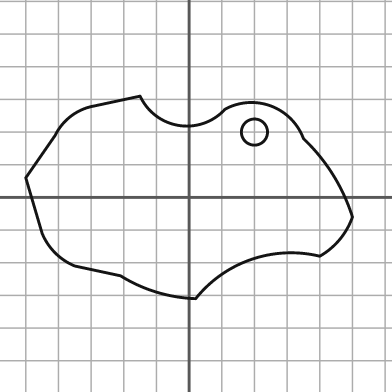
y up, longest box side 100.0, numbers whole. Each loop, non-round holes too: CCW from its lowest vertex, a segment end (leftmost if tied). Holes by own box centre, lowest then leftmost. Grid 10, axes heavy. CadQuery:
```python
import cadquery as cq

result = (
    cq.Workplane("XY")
    .moveTo(2.0, -31.0)
    .threePointArc((19.0, -19.0), (40.0, -18.0))
    .threePointArc((46.0, -13.0), (50.0, -6.0))
    .threePointArc((44.0, 7.0), (35.0, 18.0))
    .threePointArc((25.0, 28.0), (11.0, 27.0))
    .threePointArc((-3.0, 22.0), (-15.0, 31.0))
    .lineTo(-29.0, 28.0)
    .threePointArc((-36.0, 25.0), (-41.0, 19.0))
    .lineTo(-50.0, 6.0)
    .lineTo(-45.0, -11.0)
    .threePointArc((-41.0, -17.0), (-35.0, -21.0))
    .lineTo(-21.0, -24.0)
    .threePointArc((-10.0, -29.0), (2.0, -31.0))
    .close()
    .moveTo(20.0, 20.0)
    .circle(4.0)
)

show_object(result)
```